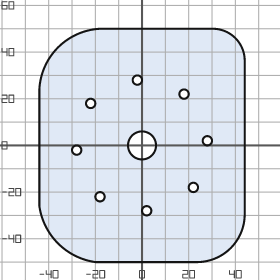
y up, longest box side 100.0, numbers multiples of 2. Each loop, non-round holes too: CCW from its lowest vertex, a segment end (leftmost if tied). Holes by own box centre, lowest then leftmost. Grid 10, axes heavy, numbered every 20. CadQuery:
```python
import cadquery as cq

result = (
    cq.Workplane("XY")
    .moveTo(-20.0, -50.0)
    .lineTo(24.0, -50.0)
    .threePointArc((38.0, -44.0), (44.0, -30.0))
    .lineTo(44.0, 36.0)
    .threePointArc((40.0, 46.0), (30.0, 50.0))
    .lineTo(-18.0, 50.0)
    .threePointArc((-36.0, 42.0), (-44.0, 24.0))
    .lineTo(-44.0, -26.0)
    .threePointArc((-36.0, -42.0), (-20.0, -50.0))
    .close()
    .moveTo(2.0, -28.0)
    .circle(2.0)
    .moveTo(-18.0, -22.0)
    .circle(2.0)
    .moveTo(22.0, -18.0)
    .circle(2.0)
    .moveTo(-28.0, -2.0)
    .circle(2.0)
    .moveTo(0.0, 0.0)
    .circle(6.0)
    .moveTo(28.0, 2.0)
    .circle(2.0)
    .moveTo(-22.0, 18.0)
    .circle(2.0)
    .moveTo(18.0, 22.0)
    .circle(2.0)
    .moveTo(-2.0, 28.0)
    .circle(2.0)
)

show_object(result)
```